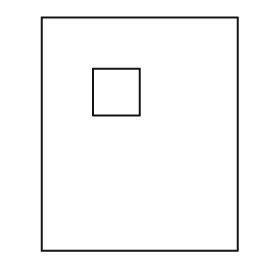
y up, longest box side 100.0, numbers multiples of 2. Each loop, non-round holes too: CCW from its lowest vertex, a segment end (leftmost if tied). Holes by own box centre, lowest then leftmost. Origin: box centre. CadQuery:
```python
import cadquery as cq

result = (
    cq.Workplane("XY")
    .moveTo(-42.0, -50.0)
    .lineTo(42.0, -50.0)
    .lineTo(42.0, 50.0)
    .lineTo(-42.0, 50.0)
    .close()
    .moveTo(-20.0, 8.0)
    .lineTo(0.0, 8.0)
    .lineTo(0.0, 28.0)
    .lineTo(-20.0, 28.0)
    .close()
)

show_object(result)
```